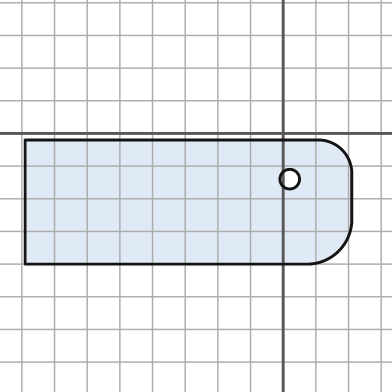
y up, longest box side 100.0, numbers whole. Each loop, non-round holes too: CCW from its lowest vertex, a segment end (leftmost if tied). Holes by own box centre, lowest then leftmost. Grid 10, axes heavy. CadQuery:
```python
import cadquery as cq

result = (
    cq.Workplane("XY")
    .moveTo(-79.0, -40.0)
    .lineTo(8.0, -40.0)
    .threePointArc((17.0, -36.0), (21.0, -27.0))
    .lineTo(21.0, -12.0)
    .threePointArc((18.0, -5.0), (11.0, -2.0))
    .lineTo(-79.0, -2.0)
    .close()
    .moveTo(2.0, -14.0)
    .circle(3.0)
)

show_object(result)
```